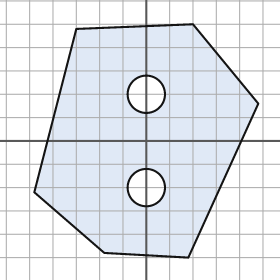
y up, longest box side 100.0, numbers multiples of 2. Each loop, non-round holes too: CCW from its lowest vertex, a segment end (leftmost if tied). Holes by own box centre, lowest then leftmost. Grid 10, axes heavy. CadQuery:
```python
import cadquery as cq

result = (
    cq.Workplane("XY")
    .moveTo(18.0, -50.0)
    .lineTo(48.0, 16.0)
    .lineTo(20.0, 50.0)
    .lineTo(-30.0, 48.0)
    .lineTo(-48.0, -22.0)
    .lineTo(-18.0, -48.0)
    .close()
    .moveTo(0.0, -20.0)
    .circle(8.0)
    .moveTo(0.0, 20.0)
    .circle(8.0)
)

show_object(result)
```